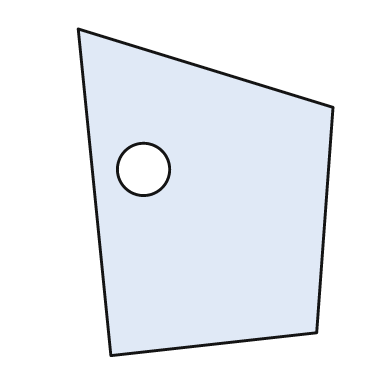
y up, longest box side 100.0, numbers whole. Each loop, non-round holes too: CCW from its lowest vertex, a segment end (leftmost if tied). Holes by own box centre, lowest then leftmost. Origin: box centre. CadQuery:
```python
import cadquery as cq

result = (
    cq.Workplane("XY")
    .moveTo(-29.0, -50.0)
    .lineTo(34.0, -43.0)
    .lineTo(39.0, 26.0)
    .lineTo(-39.0, 50.0)
    .close()
    .moveTo(-19.0, 7.0)
    .circle(8.0)
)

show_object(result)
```